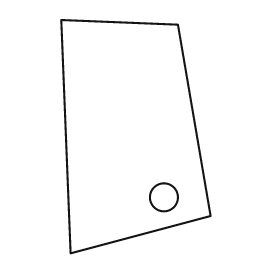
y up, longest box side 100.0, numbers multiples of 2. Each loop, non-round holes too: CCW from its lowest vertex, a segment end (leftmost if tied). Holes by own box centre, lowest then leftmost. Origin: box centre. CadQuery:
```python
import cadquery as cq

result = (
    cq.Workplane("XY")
    .moveTo(-28.0, -50.0)
    .lineTo(32.0, -34.0)
    .lineTo(18.0, 48.0)
    .lineTo(-32.0, 50.0)
    .close()
    .moveTo(12.0, -26.0)
    .circle(6.0)
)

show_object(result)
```